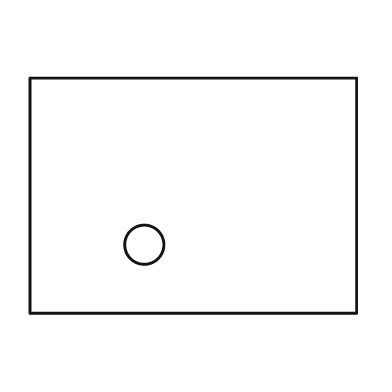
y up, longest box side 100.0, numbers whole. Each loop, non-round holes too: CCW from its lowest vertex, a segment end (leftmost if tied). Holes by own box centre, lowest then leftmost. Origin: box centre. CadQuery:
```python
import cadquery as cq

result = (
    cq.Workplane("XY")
    .moveTo(-50.0, -36.0)
    .lineTo(50.0, -36.0)
    .lineTo(50.0, 36.0)
    .lineTo(-50.0, 36.0)
    .close()
    .moveTo(-15.0, -15.0)
    .circle(6.0)
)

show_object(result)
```